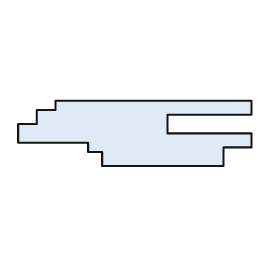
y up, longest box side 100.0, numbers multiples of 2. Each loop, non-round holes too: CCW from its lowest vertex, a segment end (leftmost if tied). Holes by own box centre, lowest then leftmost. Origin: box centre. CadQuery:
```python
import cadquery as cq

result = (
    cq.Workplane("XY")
    .moveTo(-14.0, -14.0)
    .lineTo(38.0, -14.0)
    .lineTo(38.0, -6.0)
    .lineTo(50.0, -6.0)
    .lineTo(50.0, 0.0)
    .lineTo(14.0, 0.0)
    .lineTo(14.0, 8.0)
    .lineTo(50.0, 8.0)
    .lineTo(50.0, 14.0)
    .lineTo(-34.0, 14.0)
    .lineTo(-34.0, 10.0)
    .lineTo(-42.0, 10.0)
    .lineTo(-42.0, 4.0)
    .lineTo(-50.0, 4.0)
    .lineTo(-50.0, -4.0)
    .lineTo(-20.0, -4.0)
    .lineTo(-20.0, -8.0)
    .lineTo(-14.0, -8.0)
    .close()
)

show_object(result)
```